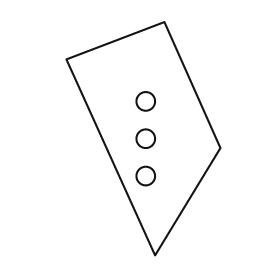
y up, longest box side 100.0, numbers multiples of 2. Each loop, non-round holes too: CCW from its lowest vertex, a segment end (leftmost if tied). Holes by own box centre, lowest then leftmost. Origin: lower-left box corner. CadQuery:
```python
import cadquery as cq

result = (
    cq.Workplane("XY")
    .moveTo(38.0, 0.0)
    .lineTo(66.0, 46.0)
    .lineTo(42.0, 100.0)
    .lineTo(0.0, 84.0)
    .close()
    .moveTo(34.0, 34.0)
    .circle(4.0)
    .moveTo(34.0, 50.0)
    .circle(4.0)
    .moveTo(34.0, 66.0)
    .circle(4.0)
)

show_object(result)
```